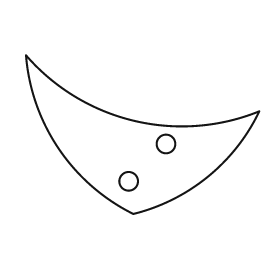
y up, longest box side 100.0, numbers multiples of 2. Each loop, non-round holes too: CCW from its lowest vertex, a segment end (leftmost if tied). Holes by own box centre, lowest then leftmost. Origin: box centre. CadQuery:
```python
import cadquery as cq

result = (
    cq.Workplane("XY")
    .moveTo(-4.0, -34.0)
    .threePointArc((28.0, -18.0), (50.0, 10.0))
    .threePointArc((-4.0, 6.0), (-50.0, 34.0))
    .threePointArc((-36.0, -6.0), (-4.0, -34.0))
    .close()
    .moveTo(-6.0, -20.0)
    .circle(4.0)
    .moveTo(10.0, -4.0)
    .circle(4.0)
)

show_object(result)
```